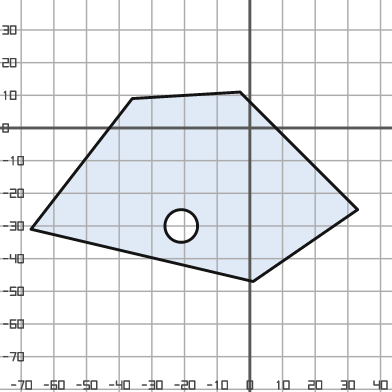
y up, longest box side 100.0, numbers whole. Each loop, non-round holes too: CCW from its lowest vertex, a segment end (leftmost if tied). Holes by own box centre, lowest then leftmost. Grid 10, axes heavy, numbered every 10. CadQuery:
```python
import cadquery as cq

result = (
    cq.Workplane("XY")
    .moveTo(1.0, -47.0)
    .lineTo(33.0, -25.0)
    .lineTo(-3.0, 11.0)
    .lineTo(-36.0, 9.0)
    .lineTo(-67.0, -31.0)
    .close()
    .moveTo(-21.0, -30.0)
    .circle(5.0)
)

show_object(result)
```